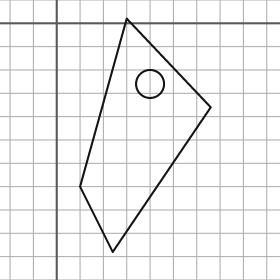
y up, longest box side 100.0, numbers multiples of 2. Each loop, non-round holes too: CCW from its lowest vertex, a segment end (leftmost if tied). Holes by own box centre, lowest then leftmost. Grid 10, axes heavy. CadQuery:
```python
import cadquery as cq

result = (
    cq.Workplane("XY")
    .moveTo(24.0, -98.0)
    .lineTo(66.0, -36.0)
    .lineTo(30.0, 2.0)
    .lineTo(10.0, -70.0)
    .close()
    .moveTo(40.0, -26.0)
    .circle(6.0)
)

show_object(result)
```